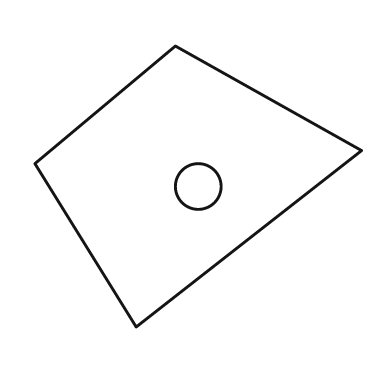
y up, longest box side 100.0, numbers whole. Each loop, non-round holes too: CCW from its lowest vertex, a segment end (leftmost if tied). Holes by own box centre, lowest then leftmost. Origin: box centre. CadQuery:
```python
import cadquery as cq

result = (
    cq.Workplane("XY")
    .moveTo(-19.0, -43.0)
    .lineTo(50.0, 11.0)
    .lineTo(-7.0, 43.0)
    .lineTo(-50.0, 7.0)
    .close()
    .moveTo(0.0, 0.0)
    .circle(7.0)
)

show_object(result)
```